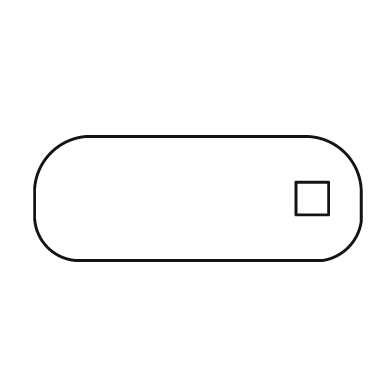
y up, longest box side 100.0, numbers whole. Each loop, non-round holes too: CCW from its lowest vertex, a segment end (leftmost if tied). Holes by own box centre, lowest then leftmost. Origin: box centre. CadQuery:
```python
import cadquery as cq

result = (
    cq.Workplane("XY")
    .moveTo(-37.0, -19.0)
    .lineTo(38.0, -19.0)
    .threePointArc((46.0, -15.0), (50.0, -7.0))
    .lineTo(50.0, 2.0)
    .threePointArc((45.0, 14.0), (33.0, 19.0))
    .lineTo(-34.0, 19.0)
    .threePointArc((-45.0, 14.0), (-50.0, 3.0))
    .lineTo(-50.0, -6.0)
    .threePointArc((-46.0, -15.0), (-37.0, -19.0))
    .close()
    .moveTo(30.0, -5.0)
    .lineTo(40.0, -5.0)
    .lineTo(40.0, 5.0)
    .lineTo(30.0, 5.0)
    .close()
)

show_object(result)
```